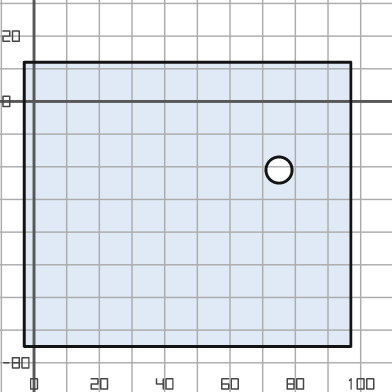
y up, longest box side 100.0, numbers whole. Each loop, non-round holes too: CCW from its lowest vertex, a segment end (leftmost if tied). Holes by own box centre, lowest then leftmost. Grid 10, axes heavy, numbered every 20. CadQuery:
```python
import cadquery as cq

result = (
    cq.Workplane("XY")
    .moveTo(-3.0, -75.0)
    .lineTo(97.0, -75.0)
    .lineTo(97.0, 12.0)
    .lineTo(-3.0, 12.0)
    .close()
    .moveTo(75.0, -21.0)
    .circle(4.0)
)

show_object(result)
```